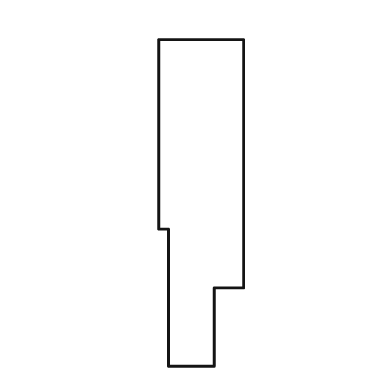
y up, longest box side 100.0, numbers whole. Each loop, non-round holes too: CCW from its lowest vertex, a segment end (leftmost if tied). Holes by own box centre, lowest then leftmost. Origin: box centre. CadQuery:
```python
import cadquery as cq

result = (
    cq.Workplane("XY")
    .moveTo(-10.0, -50.0)
    .lineTo(4.0, -50.0)
    .lineTo(4.0, -26.0)
    .lineTo(13.0, -26.0)
    .lineTo(13.0, 50.0)
    .lineTo(-13.0, 50.0)
    .lineTo(-13.0, -8.0)
    .lineTo(-10.0, -8.0)
    .close()
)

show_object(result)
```